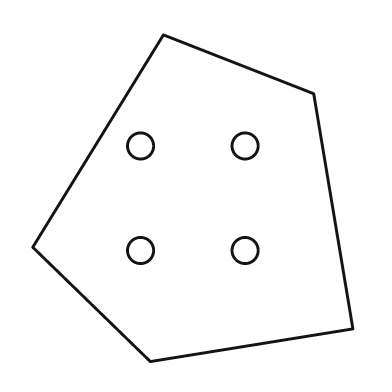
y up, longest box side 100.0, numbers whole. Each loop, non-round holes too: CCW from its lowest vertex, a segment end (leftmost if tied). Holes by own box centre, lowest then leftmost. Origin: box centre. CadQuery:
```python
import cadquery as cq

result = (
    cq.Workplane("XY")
    .moveTo(-13.0, -50.0)
    .lineTo(49.0, -40.0)
    .lineTo(37.0, 32.0)
    .lineTo(-9.0, 50.0)
    .lineTo(-49.0, -15.0)
    .close()
    .moveTo(-16.0, -16.0)
    .circle(4.0)
    .moveTo(16.0, -16.0)
    .circle(4.0)
    .moveTo(-16.0, 16.0)
    .circle(4.0)
    .moveTo(16.0, 16.0)
    .circle(4.0)
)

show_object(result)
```